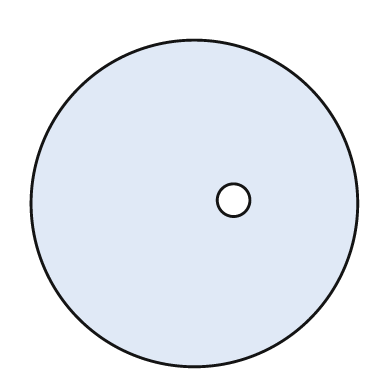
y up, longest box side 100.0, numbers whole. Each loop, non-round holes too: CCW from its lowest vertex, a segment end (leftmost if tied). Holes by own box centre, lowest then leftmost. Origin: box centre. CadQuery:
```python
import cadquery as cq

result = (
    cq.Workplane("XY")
    .moveTo(0.0, 0.0)
    .circle(50.0)
    .moveTo(12.0, 1.0)
    .circle(5.0)
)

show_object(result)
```